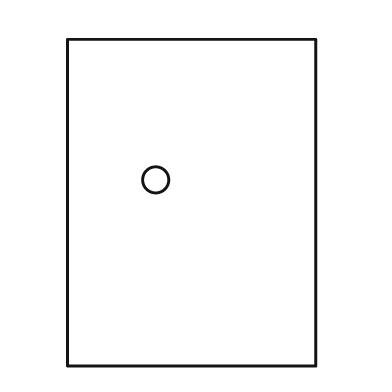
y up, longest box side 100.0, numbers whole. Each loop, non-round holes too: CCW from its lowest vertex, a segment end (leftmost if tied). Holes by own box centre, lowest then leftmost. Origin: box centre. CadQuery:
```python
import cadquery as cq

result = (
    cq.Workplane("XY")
    .moveTo(-38.0, -50.0)
    .lineTo(38.0, -50.0)
    .lineTo(38.0, 50.0)
    .lineTo(-38.0, 50.0)
    .close()
    .moveTo(-11.0, 7.0)
    .circle(4.0)
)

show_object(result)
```